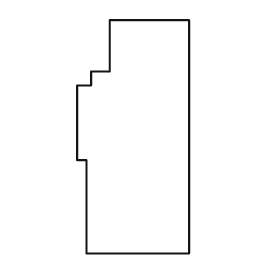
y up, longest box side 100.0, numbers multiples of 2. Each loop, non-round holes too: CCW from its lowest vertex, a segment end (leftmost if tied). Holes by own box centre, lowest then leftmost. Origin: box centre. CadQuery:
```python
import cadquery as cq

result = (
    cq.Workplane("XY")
    .moveTo(-20.0, -50.0)
    .lineTo(24.0, -50.0)
    .lineTo(24.0, 50.0)
    .lineTo(-10.0, 50.0)
    .lineTo(-10.0, 28.0)
    .lineTo(-18.0, 28.0)
    .lineTo(-18.0, 22.0)
    .lineTo(-24.0, 22.0)
    .lineTo(-24.0, -10.0)
    .lineTo(-20.0, -10.0)
    .close()
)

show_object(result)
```